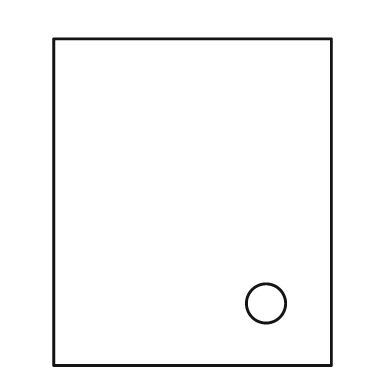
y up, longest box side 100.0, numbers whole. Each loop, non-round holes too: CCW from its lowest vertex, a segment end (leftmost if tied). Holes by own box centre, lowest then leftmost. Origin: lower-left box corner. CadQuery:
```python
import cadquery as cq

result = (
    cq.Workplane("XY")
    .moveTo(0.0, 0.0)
    .lineTo(85.0, 0.0)
    .lineTo(85.0, 100.0)
    .lineTo(0.0, 100.0)
    .close()
    .moveTo(65.0, 19.0)
    .circle(6.0)
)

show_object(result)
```